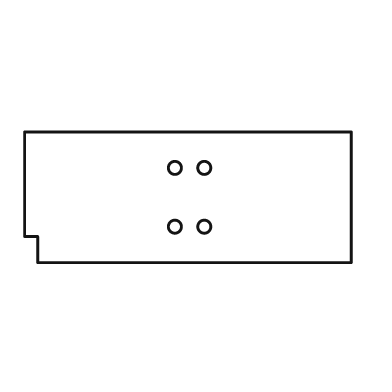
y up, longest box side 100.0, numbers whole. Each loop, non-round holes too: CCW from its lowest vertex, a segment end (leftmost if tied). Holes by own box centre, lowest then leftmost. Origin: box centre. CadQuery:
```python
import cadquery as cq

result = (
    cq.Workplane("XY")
    .moveTo(-46.0, -20.0)
    .lineTo(50.0, -20.0)
    .lineTo(50.0, 20.0)
    .lineTo(-50.0, 20.0)
    .lineTo(-50.0, -12.0)
    .lineTo(-46.0, -12.0)
    .close()
    .moveTo(-4.0, -9.0)
    .circle(2.0)
    .moveTo(5.0, -9.0)
    .circle(2.0)
    .moveTo(-4.0, 9.0)
    .circle(2.0)
    .moveTo(5.0, 9.0)
    .circle(2.0)
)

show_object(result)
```